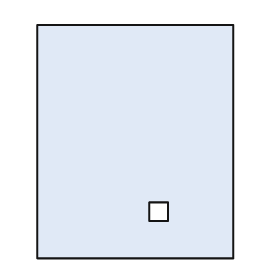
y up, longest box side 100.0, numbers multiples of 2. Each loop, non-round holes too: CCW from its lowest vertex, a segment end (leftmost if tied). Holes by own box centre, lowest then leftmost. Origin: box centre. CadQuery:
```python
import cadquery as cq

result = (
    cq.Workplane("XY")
    .moveTo(-42.0, -50.0)
    .lineTo(42.0, -50.0)
    .lineTo(42.0, 50.0)
    .lineTo(-42.0, 50.0)
    .close()
    .moveTo(6.0, -34.0)
    .lineTo(14.0, -34.0)
    .lineTo(14.0, -26.0)
    .lineTo(6.0, -26.0)
    .close()
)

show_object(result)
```